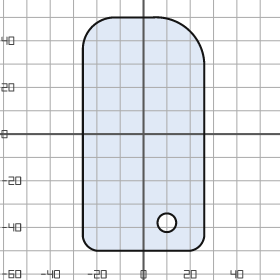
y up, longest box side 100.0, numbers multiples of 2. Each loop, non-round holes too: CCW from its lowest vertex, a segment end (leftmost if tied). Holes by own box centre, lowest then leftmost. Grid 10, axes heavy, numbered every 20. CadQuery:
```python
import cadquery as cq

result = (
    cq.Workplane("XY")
    .moveTo(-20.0, -50.0)
    .lineTo(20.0, -50.0)
    .threePointArc((24.0, -48.0), (26.0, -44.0))
    .lineTo(26.0, 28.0)
    .threePointArc((20.0, 44.0), (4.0, 50.0))
    .lineTo(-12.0, 50.0)
    .threePointArc((-22.0, 46.0), (-26.0, 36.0))
    .lineTo(-26.0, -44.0)
    .threePointArc((-24.0, -48.0), (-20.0, -50.0))
    .close()
    .moveTo(10.0, -38.0)
    .circle(4.0)
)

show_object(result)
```